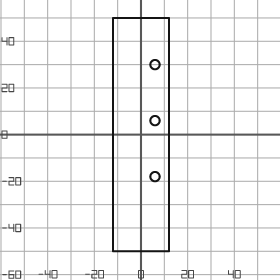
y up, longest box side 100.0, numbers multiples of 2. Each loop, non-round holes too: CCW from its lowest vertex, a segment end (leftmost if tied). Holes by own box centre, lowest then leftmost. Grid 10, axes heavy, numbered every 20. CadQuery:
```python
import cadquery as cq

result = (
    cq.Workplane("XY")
    .moveTo(-12.0, -50.0)
    .lineTo(12.0, -50.0)
    .lineTo(12.0, 50.0)
    .lineTo(-12.0, 50.0)
    .close()
    .moveTo(6.0, -18.0)
    .circle(2.0)
    .moveTo(6.0, 6.0)
    .circle(2.0)
    .moveTo(6.0, 30.0)
    .circle(2.0)
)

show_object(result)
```